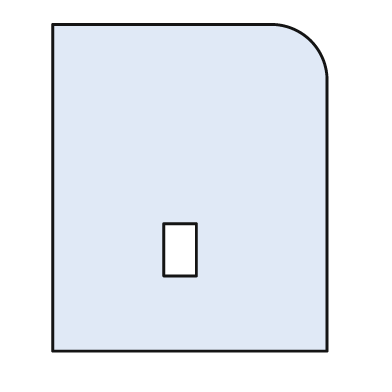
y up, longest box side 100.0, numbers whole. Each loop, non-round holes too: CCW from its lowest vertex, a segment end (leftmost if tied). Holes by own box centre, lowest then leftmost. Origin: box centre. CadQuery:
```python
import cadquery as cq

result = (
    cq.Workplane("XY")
    .moveTo(-42.0, -50.0)
    .lineTo(42.0, -50.0)
    .lineTo(42.0, 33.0)
    .threePointArc((37.0, 45.0), (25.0, 50.0))
    .lineTo(-42.0, 50.0)
    .close()
    .moveTo(-8.0, -27.0)
    .lineTo(2.0, -27.0)
    .lineTo(2.0, -11.0)
    .lineTo(-8.0, -11.0)
    .close()
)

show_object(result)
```